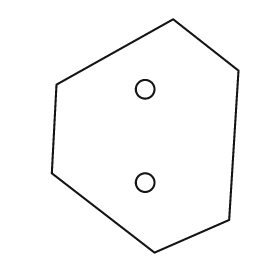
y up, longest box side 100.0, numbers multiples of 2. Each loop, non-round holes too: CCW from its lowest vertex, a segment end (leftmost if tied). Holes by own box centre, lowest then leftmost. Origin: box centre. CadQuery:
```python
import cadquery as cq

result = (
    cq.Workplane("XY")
    .moveTo(4.0, -50.0)
    .lineTo(36.0, -36.0)
    .lineTo(40.0, 28.0)
    .lineTo(12.0, 50.0)
    .lineTo(-38.0, 22.0)
    .lineTo(-40.0, -16.0)
    .close()
    .moveTo(0.0, -20.0)
    .circle(4.0)
    .moveTo(0.0, 20.0)
    .circle(4.0)
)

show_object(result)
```